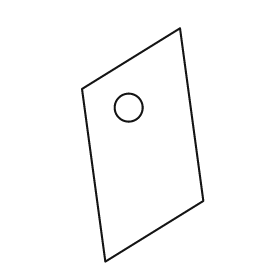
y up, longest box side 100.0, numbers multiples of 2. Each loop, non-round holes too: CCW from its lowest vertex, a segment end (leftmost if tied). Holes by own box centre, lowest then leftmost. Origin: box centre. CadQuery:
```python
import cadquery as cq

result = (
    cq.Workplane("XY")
    .moveTo(-16.0, -50.0)
    .lineTo(26.0, -24.0)
    .lineTo(16.0, 50.0)
    .lineTo(-26.0, 24.0)
    .close()
    .moveTo(-6.0, 16.0)
    .circle(6.0)
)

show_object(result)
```